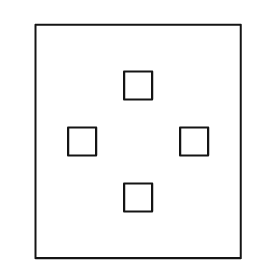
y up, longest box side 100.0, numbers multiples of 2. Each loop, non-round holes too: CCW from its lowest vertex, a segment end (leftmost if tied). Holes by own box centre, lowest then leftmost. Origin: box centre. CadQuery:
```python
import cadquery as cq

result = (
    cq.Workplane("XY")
    .moveTo(-44.0, -50.0)
    .lineTo(44.0, -50.0)
    .lineTo(44.0, 50.0)
    .lineTo(-44.0, 50.0)
    .close()
    .moveTo(-6.0, -30.0)
    .lineTo(6.0, -30.0)
    .lineTo(6.0, -18.0)
    .lineTo(-6.0, -18.0)
    .close()
    .moveTo(-30.0, -6.0)
    .lineTo(-18.0, -6.0)
    .lineTo(-18.0, 6.0)
    .lineTo(-30.0, 6.0)
    .close()
    .moveTo(18.0, -6.0)
    .lineTo(30.0, -6.0)
    .lineTo(30.0, 6.0)
    .lineTo(18.0, 6.0)
    .close()
    .moveTo(-6.0, 18.0)
    .lineTo(6.0, 18.0)
    .lineTo(6.0, 30.0)
    .lineTo(-6.0, 30.0)
    .close()
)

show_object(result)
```